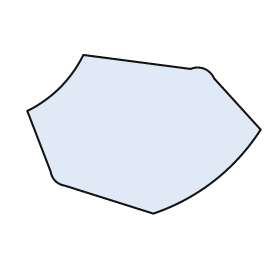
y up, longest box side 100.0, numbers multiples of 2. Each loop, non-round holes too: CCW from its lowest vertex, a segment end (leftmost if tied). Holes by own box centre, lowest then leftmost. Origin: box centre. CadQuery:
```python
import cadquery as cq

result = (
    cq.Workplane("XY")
    .moveTo(4.0, -34.0)
    .threePointArc((30.0, -20.0), (50.0, 2.0))
    .lineTo(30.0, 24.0)
    .threePointArc((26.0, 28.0), (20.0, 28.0))
    .lineTo(-26.0, 34.0)
    .threePointArc((-36.0, 20.0), (-50.0, 10.0))
    .lineTo(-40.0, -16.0)
    .threePointArc((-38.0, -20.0), (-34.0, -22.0))
    .close()
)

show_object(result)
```